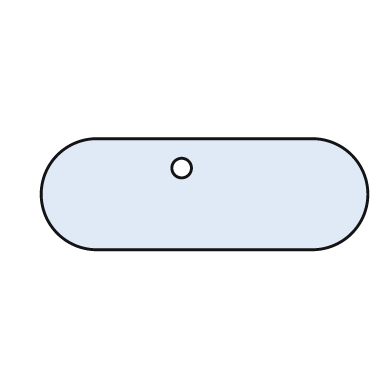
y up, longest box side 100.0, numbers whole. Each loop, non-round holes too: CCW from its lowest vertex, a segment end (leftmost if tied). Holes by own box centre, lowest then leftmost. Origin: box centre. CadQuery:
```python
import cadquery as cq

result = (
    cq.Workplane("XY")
    .moveTo(-33.0, -17.0)
    .lineTo(33.0, -17.0)
    .threePointArc((50.0, 0.0), (33.0, 17.0))
    .lineTo(-33.0, 17.0)
    .threePointArc((-50.0, 0.0), (-33.0, -17.0))
    .close()
    .moveTo(-7.0, 8.0)
    .circle(3.0)
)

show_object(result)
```